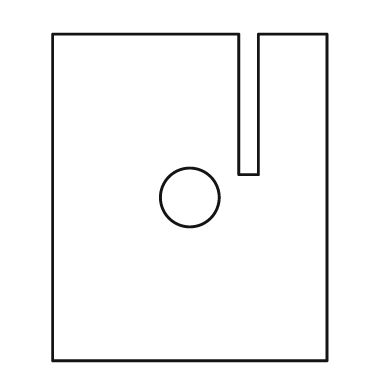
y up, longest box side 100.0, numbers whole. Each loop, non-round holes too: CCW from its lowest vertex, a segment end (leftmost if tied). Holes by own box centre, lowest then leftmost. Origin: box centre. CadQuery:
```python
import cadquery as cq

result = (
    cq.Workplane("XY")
    .moveTo(-42.0, -50.0)
    .lineTo(42.0, -50.0)
    .lineTo(42.0, 50.0)
    .lineTo(21.0, 50.0)
    .lineTo(21.0, 7.0)
    .lineTo(15.0, 7.0)
    .lineTo(15.0, 50.0)
    .lineTo(-42.0, 50.0)
    .close()
    .moveTo(0.0, 0.0)
    .circle(9.0)
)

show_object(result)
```